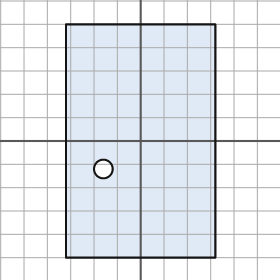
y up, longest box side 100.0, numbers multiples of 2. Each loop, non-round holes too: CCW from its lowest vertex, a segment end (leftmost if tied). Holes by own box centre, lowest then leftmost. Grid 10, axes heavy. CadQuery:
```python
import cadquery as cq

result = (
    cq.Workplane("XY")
    .moveTo(-32.0, -50.0)
    .lineTo(32.0, -50.0)
    .lineTo(32.0, 50.0)
    .lineTo(-32.0, 50.0)
    .close()
    .moveTo(-16.0, -12.0)
    .circle(4.0)
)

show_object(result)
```